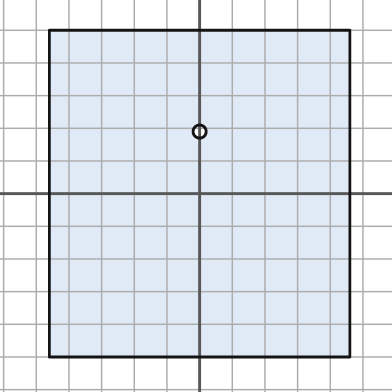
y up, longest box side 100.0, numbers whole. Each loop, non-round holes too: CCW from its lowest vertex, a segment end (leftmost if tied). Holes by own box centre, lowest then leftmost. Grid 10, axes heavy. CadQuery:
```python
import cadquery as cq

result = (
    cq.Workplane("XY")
    .moveTo(-46.0, -50.0)
    .lineTo(46.0, -50.0)
    .lineTo(46.0, 50.0)
    .lineTo(-46.0, 50.0)
    .close()
    .moveTo(0.0, 19.0)
    .circle(2.0)
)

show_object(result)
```